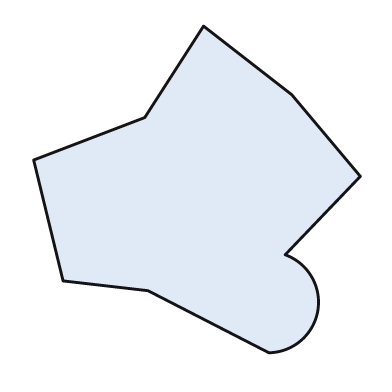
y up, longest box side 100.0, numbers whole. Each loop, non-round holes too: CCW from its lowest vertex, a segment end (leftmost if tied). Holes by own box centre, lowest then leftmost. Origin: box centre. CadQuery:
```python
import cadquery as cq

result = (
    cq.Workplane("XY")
    .moveTo(22.0, -50.0)
    .threePointArc((37.0, -37.0), (27.0, -20.0))
    .lineTo(50.0, 4.0)
    .lineTo(29.0, 29.0)
    .lineTo(2.0, 50.0)
    .lineTo(-16.0, 22.0)
    .lineTo(-50.0, 9.0)
    .lineTo(-41.0, -28.0)
    .lineTo(-15.0, -31.0)
    .close()
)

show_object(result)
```